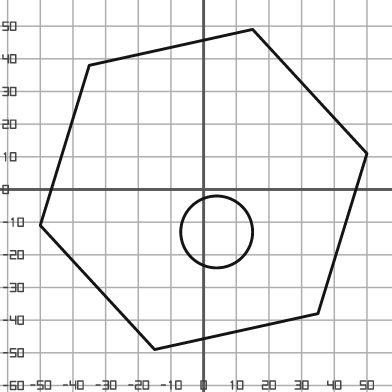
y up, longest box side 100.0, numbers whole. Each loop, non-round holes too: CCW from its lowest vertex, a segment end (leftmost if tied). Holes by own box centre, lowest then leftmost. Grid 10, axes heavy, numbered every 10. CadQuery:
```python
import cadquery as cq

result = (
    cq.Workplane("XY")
    .moveTo(-15.0, -49.0)
    .lineTo(35.0, -38.0)
    .lineTo(50.0, 11.0)
    .lineTo(15.0, 49.0)
    .lineTo(-35.0, 38.0)
    .lineTo(-50.0, -11.0)
    .close()
    .moveTo(4.0, -13.0)
    .circle(11.0)
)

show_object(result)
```